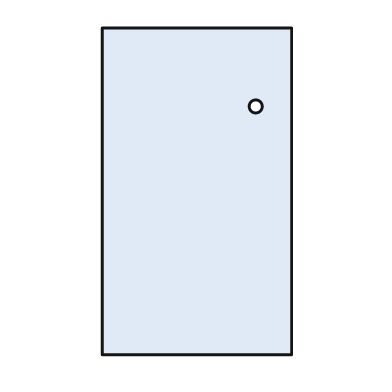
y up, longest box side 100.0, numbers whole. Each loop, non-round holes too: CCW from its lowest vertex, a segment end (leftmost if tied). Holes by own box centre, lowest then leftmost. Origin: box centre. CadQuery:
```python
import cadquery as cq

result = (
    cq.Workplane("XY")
    .moveTo(-29.0, -50.0)
    .lineTo(29.0, -50.0)
    .lineTo(29.0, 50.0)
    .lineTo(-29.0, 50.0)
    .close()
    .moveTo(18.0, 26.0)
    .circle(2.0)
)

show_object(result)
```